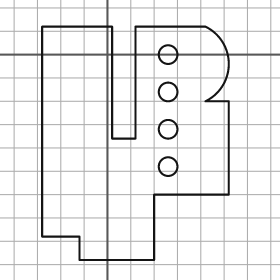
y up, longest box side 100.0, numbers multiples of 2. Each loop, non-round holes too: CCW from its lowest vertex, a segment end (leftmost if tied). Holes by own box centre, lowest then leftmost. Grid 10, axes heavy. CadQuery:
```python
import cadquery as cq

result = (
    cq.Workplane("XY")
    .moveTo(-12.0, -88.0)
    .lineTo(20.0, -88.0)
    .lineTo(20.0, -60.0)
    .lineTo(52.0, -60.0)
    .lineTo(52.0, -20.0)
    .lineTo(42.0, -20.0)
    .threePointArc((52.0, -4.0), (42.0, 12.0))
    .lineTo(12.0, 12.0)
    .lineTo(12.0, -36.0)
    .lineTo(2.0, -36.0)
    .lineTo(2.0, 12.0)
    .lineTo(-28.0, 12.0)
    .lineTo(-28.0, -78.0)
    .lineTo(-12.0, -78.0)
    .close()
    .moveTo(26.0, -48.0)
    .circle(4.0)
    .moveTo(26.0, -32.0)
    .circle(4.0)
    .moveTo(26.0, -16.0)
    .circle(4.0)
    .moveTo(26.0, 0.0)
    .circle(4.0)
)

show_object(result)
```